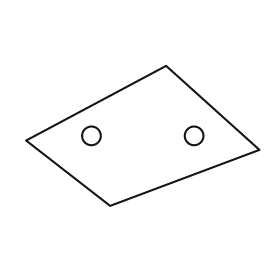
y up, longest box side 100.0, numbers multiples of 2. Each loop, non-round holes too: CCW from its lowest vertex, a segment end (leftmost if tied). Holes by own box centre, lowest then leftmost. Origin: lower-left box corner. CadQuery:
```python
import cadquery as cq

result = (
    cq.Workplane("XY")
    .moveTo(36.0, 0.0)
    .lineTo(100.0, 24.0)
    .lineTo(60.0, 60.0)
    .lineTo(0.0, 28.0)
    .close()
    .moveTo(28.0, 30.0)
    .circle(4.0)
    .moveTo(72.0, 30.0)
    .circle(4.0)
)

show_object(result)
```